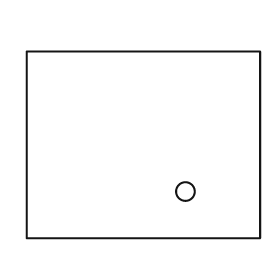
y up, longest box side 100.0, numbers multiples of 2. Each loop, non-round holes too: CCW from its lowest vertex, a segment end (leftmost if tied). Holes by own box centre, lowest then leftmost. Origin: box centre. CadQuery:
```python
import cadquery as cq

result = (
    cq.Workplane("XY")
    .moveTo(-50.0, -40.0)
    .lineTo(50.0, -40.0)
    .lineTo(50.0, 40.0)
    .lineTo(-50.0, 40.0)
    .close()
    .moveTo(18.0, -20.0)
    .circle(4.0)
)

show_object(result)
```